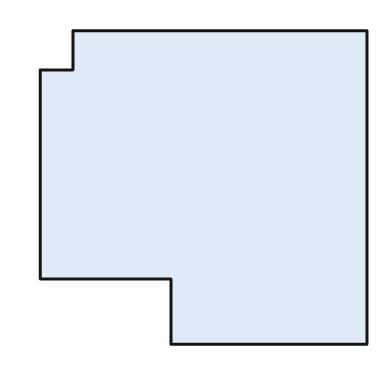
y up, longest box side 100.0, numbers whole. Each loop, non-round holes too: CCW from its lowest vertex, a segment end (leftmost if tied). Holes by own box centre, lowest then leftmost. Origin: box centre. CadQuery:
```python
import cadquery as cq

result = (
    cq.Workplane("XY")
    .moveTo(-10.0, -48.0)
    .lineTo(50.0, -48.0)
    .lineTo(50.0, 48.0)
    .lineTo(-40.0, 48.0)
    .lineTo(-40.0, 36.0)
    .lineTo(-50.0, 36.0)
    .lineTo(-50.0, -28.0)
    .lineTo(-10.0, -28.0)
    .close()
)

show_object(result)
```